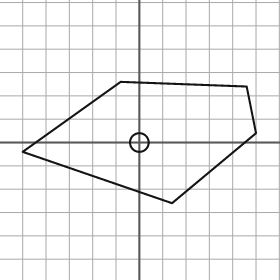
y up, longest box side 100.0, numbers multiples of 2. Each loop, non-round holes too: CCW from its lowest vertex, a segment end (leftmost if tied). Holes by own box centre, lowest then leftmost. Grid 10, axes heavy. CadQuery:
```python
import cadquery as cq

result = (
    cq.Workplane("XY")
    .moveTo(14.0, -26.0)
    .lineTo(50.0, 4.0)
    .lineTo(46.0, 24.0)
    .lineTo(-8.0, 26.0)
    .lineTo(-50.0, -4.0)
    .close()
    .moveTo(0.0, 0.0)
    .circle(4.0)
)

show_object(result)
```